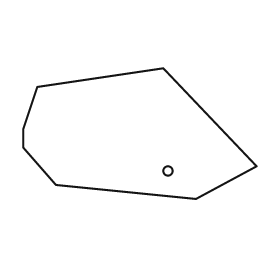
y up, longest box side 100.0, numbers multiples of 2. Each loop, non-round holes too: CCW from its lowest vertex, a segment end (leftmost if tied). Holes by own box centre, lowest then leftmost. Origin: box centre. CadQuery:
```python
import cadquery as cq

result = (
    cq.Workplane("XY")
    .moveTo(24.0, -28.0)
    .lineTo(50.0, -14.0)
    .lineTo(10.0, 28.0)
    .lineTo(-44.0, 20.0)
    .lineTo(-50.0, 2.0)
    .lineTo(-50.0, -6.0)
    .lineTo(-36.0, -22.0)
    .close()
    .moveTo(12.0, -16.0)
    .circle(2.0)
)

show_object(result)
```